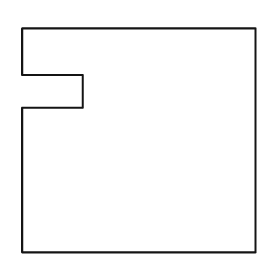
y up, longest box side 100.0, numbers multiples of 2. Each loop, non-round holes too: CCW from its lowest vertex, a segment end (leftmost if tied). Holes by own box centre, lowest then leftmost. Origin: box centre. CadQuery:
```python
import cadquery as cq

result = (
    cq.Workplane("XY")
    .moveTo(-50.0, -48.0)
    .lineTo(50.0, -48.0)
    .lineTo(50.0, 48.0)
    .lineTo(-50.0, 48.0)
    .lineTo(-50.0, 28.0)
    .lineTo(-24.0, 28.0)
    .lineTo(-24.0, 14.0)
    .lineTo(-50.0, 14.0)
    .close()
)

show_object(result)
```